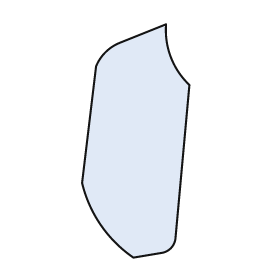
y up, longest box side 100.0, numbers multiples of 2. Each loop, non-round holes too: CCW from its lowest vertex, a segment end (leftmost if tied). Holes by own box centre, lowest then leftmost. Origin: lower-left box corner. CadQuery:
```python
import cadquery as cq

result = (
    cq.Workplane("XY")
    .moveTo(22.0, 0.0)
    .lineTo(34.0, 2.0)
    .threePointArc((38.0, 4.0), (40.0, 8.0))
    .lineTo(46.0, 74.0)
    .threePointArc((38.0, 86.0), (36.0, 100.0))
    .lineTo(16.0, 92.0)
    .threePointArc((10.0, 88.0), (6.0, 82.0))
    .lineTo(0.0, 32.0)
    .threePointArc((8.0, 14.0), (22.0, 0.0))
    .close()
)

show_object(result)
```